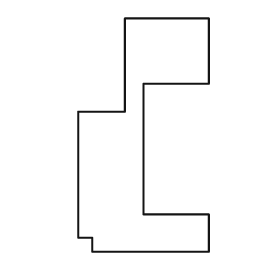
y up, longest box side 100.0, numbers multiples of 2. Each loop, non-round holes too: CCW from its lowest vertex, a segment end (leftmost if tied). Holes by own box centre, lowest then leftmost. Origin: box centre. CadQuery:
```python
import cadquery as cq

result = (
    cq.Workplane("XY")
    .moveTo(-22.0, -50.0)
    .lineTo(28.0, -50.0)
    .lineTo(28.0, -34.0)
    .lineTo(0.0, -34.0)
    .lineTo(0.0, 22.0)
    .lineTo(28.0, 22.0)
    .lineTo(28.0, 50.0)
    .lineTo(-8.0, 50.0)
    .lineTo(-8.0, 10.0)
    .lineTo(-28.0, 10.0)
    .lineTo(-28.0, -44.0)
    .lineTo(-22.0, -44.0)
    .close()
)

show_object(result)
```